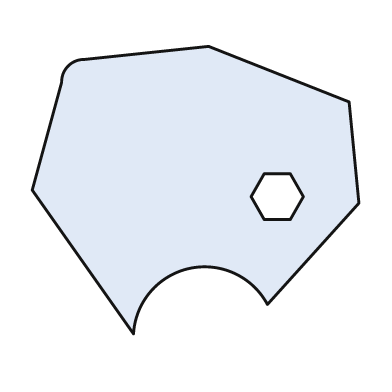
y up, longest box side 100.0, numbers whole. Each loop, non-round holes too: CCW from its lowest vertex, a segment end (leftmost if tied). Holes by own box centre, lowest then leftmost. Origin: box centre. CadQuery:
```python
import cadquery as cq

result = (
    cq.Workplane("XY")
    .moveTo(-19.0, -44.0)
    .threePointArc((-2.0, -24.0), (22.0, -35.0))
    .lineTo(50.0, -4.0)
    .lineTo(47.0, 27.0)
    .lineTo(4.0, 44.0)
    .lineTo(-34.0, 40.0)
    .threePointArc((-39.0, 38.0), (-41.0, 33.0))
    .lineTo(-50.0, 0.0)
    .close()
    .moveTo(21.0, -9.0)
    .lineTo(29.0, -9.0)
    .lineTo(33.0, -2.0)
    .lineTo(29.0, 5.0)
    .lineTo(21.0, 5.0)
    .lineTo(17.0, -2.0)
    .close()
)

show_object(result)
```